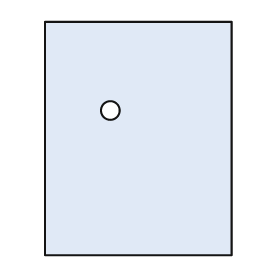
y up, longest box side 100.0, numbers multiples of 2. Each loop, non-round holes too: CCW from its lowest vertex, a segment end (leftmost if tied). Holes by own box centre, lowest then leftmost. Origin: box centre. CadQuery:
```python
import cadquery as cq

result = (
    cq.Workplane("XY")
    .moveTo(-40.0, -50.0)
    .lineTo(40.0, -50.0)
    .lineTo(40.0, 50.0)
    .lineTo(-40.0, 50.0)
    .close()
    .moveTo(-12.0, 12.0)
    .circle(4.0)
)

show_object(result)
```